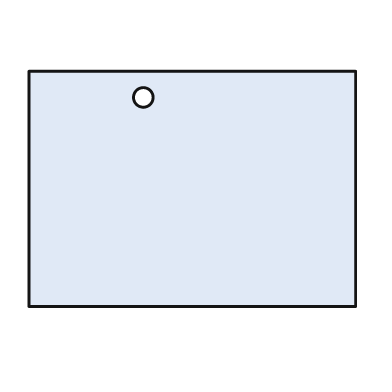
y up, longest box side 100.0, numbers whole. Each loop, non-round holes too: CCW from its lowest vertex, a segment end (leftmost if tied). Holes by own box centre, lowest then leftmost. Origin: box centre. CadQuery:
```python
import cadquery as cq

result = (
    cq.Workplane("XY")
    .moveTo(-50.0, -36.0)
    .lineTo(50.0, -36.0)
    .lineTo(50.0, 36.0)
    .lineTo(-50.0, 36.0)
    .close()
    .moveTo(-15.0, 28.0)
    .circle(3.0)
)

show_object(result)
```